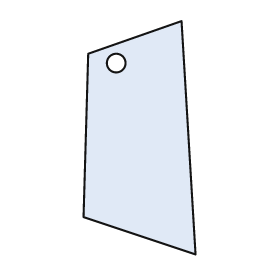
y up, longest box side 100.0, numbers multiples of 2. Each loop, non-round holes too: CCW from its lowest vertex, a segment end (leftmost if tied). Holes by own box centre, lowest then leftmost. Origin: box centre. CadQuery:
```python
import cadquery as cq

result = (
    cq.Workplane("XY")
    .moveTo(24.0, -50.0)
    .lineTo(18.0, 50.0)
    .lineTo(-22.0, 36.0)
    .lineTo(-24.0, -34.0)
    .close()
    .moveTo(-10.0, 32.0)
    .circle(4.0)
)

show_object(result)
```